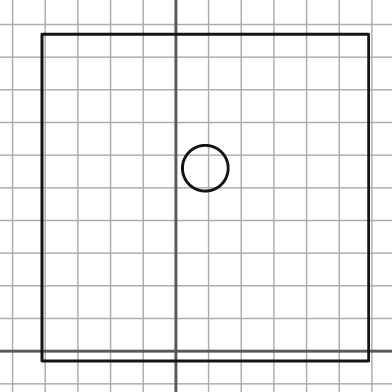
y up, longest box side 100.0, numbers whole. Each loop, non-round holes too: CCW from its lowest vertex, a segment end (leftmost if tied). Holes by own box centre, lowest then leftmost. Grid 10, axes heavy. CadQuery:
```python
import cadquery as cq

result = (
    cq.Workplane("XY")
    .moveTo(-41.0, -3.0)
    .lineTo(59.0, -3.0)
    .lineTo(59.0, 97.0)
    .lineTo(-41.0, 97.0)
    .close()
    .moveTo(9.0, 56.0)
    .circle(7.0)
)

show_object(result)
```